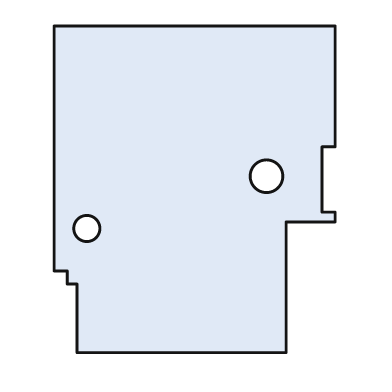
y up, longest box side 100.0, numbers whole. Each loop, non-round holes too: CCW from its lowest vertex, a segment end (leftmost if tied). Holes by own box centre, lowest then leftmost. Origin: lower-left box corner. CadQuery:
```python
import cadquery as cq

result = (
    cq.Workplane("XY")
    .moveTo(7.0, 0.0)
    .lineTo(71.0, 0.0)
    .lineTo(71.0, 40.0)
    .lineTo(86.0, 40.0)
    .lineTo(86.0, 43.0)
    .lineTo(82.0, 43.0)
    .lineTo(82.0, 63.0)
    .lineTo(86.0, 63.0)
    .lineTo(86.0, 100.0)
    .lineTo(0.0, 100.0)
    .lineTo(0.0, 25.0)
    .lineTo(4.0, 25.0)
    .lineTo(4.0, 21.0)
    .lineTo(7.0, 21.0)
    .close()
    .moveTo(10.0, 38.0)
    .circle(4.0)
    .moveTo(65.0, 54.0)
    .circle(5.0)
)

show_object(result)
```